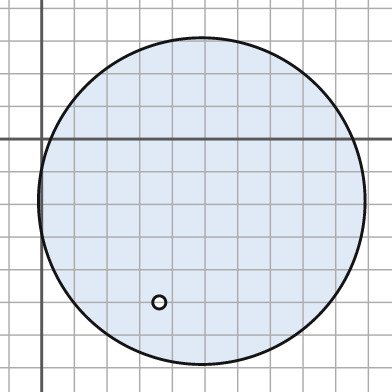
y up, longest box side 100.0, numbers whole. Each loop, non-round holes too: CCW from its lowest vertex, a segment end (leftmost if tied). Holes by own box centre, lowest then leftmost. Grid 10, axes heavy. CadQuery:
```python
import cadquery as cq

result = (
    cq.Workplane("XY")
    .moveTo(49.0, -19.0)
    .circle(50.0)
    .moveTo(36.0, -50.0)
    .circle(2.0)
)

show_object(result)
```